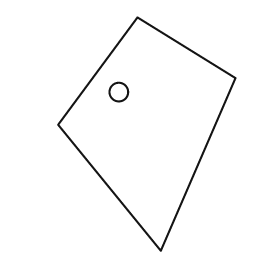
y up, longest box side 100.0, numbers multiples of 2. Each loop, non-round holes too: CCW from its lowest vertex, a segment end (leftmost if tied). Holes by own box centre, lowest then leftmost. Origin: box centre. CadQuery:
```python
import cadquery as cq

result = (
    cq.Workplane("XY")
    .moveTo(6.0, -50.0)
    .lineTo(38.0, 24.0)
    .lineTo(-4.0, 50.0)
    .lineTo(-38.0, 4.0)
    .close()
    .moveTo(-12.0, 18.0)
    .circle(4.0)
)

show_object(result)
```